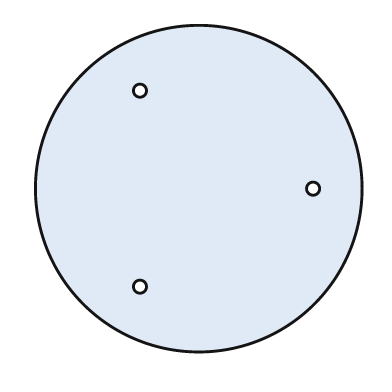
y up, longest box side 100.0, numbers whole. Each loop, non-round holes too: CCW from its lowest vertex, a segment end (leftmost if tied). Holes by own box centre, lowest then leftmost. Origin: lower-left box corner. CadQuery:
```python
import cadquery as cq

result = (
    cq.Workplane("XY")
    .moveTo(50.0, 50.0)
    .circle(50.0)
    .moveTo(32.0, 20.0)
    .circle(2.0)
    .moveTo(85.0, 50.0)
    .circle(2.0)
    .moveTo(32.0, 80.0)
    .circle(2.0)
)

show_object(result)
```